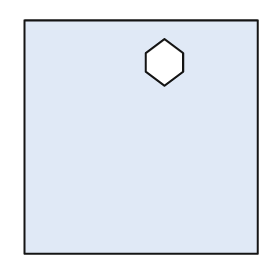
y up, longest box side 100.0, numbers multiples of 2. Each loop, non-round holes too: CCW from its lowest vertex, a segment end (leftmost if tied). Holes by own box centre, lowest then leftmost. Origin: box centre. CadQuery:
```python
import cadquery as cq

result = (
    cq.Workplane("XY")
    .moveTo(-50.0, -50.0)
    .lineTo(50.0, -50.0)
    .lineTo(50.0, 50.0)
    .lineTo(-50.0, 50.0)
    .close()
    .moveTo(10.0, 22.0)
    .lineTo(18.0, 28.0)
    .lineTo(18.0, 36.0)
    .lineTo(10.0, 42.0)
    .lineTo(2.0, 36.0)
    .lineTo(2.0, 28.0)
    .close()
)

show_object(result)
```